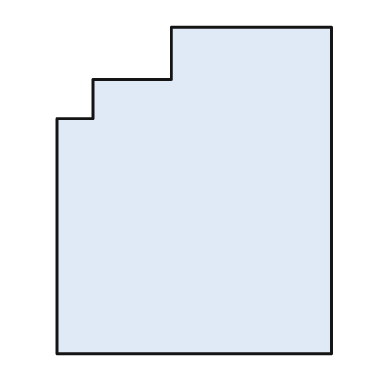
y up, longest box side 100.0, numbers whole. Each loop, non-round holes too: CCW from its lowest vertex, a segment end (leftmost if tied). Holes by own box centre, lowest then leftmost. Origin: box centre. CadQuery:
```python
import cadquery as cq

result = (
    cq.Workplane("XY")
    .moveTo(-42.0, -50.0)
    .lineTo(42.0, -50.0)
    .lineTo(42.0, 50.0)
    .lineTo(-7.0, 50.0)
    .lineTo(-7.0, 34.0)
    .lineTo(-31.0, 34.0)
    .lineTo(-31.0, 22.0)
    .lineTo(-42.0, 22.0)
    .close()
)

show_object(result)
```